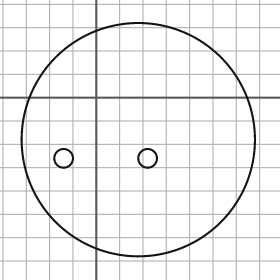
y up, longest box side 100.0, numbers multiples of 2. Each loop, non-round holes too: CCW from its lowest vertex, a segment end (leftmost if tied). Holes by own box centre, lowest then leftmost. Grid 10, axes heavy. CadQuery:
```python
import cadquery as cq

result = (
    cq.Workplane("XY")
    .moveTo(18.0, -18.0)
    .circle(50.0)
    .moveTo(-14.0, -26.0)
    .circle(4.0)
    .moveTo(22.0, -26.0)
    .circle(4.0)
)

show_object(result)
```